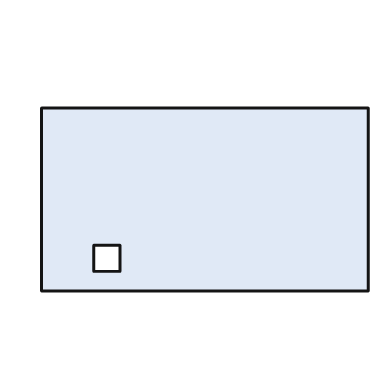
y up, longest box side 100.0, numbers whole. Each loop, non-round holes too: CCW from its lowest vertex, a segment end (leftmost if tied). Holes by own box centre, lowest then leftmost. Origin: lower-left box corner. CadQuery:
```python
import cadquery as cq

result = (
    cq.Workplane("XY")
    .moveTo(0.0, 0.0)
    .lineTo(100.0, 0.0)
    .lineTo(100.0, 56.0)
    .lineTo(0.0, 56.0)
    .close()
    .moveTo(16.0, 6.0)
    .lineTo(24.0, 6.0)
    .lineTo(24.0, 14.0)
    .lineTo(16.0, 14.0)
    .close()
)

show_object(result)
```